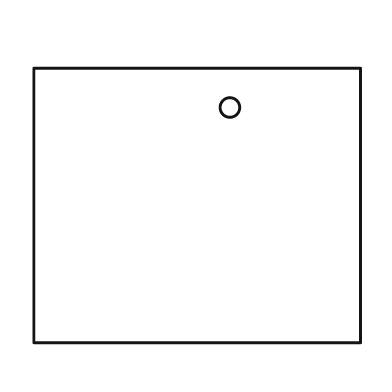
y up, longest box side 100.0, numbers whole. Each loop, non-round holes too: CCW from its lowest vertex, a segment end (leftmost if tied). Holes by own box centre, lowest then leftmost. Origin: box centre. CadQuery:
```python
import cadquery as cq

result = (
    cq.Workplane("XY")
    .moveTo(-50.0, -42.0)
    .lineTo(50.0, -42.0)
    .lineTo(50.0, 42.0)
    .lineTo(-50.0, 42.0)
    .close()
    .moveTo(10.0, 30.0)
    .circle(3.0)
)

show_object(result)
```